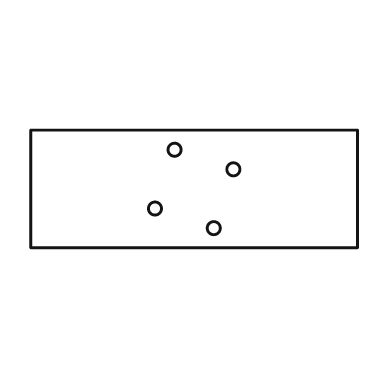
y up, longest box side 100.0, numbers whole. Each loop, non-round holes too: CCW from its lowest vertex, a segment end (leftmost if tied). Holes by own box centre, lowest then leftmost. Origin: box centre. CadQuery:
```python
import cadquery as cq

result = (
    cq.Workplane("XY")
    .moveTo(-50.0, -18.0)
    .lineTo(50.0, -18.0)
    .lineTo(50.0, 18.0)
    .lineTo(-50.0, 18.0)
    .close()
    .moveTo(6.0, -12.0)
    .circle(2.0)
    .moveTo(-12.0, -6.0)
    .circle(2.0)
    .moveTo(12.0, 6.0)
    .circle(2.0)
    .moveTo(-6.0, 12.0)
    .circle(2.0)
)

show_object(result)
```